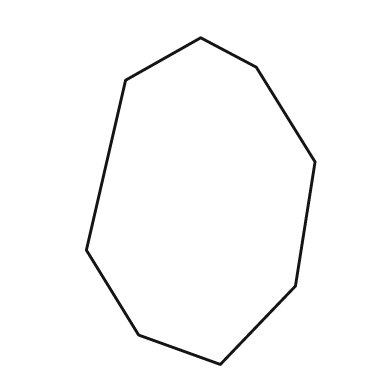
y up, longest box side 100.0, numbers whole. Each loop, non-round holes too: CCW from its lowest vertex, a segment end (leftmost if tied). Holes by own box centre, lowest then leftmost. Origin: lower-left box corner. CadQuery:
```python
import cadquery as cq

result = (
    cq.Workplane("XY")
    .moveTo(41.0, 0.0)
    .lineTo(64.0, 24.0)
    .lineTo(70.0, 62.0)
    .lineTo(52.0, 91.0)
    .lineTo(35.0, 100.0)
    .lineTo(12.0, 87.0)
    .lineTo(0.0, 35.0)
    .lineTo(16.0, 9.0)
    .close()
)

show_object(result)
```